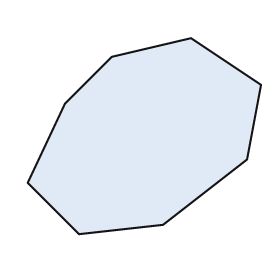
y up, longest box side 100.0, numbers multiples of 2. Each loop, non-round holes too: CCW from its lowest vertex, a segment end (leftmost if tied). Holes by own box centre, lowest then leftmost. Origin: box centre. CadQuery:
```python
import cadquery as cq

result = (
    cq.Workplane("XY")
    .moveTo(-28.0, -42.0)
    .lineTo(8.0, -38.0)
    .lineTo(44.0, -10.0)
    .lineTo(50.0, 22.0)
    .lineTo(20.0, 42.0)
    .lineTo(-14.0, 34.0)
    .lineTo(-34.0, 14.0)
    .lineTo(-50.0, -20.0)
    .close()
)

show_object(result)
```